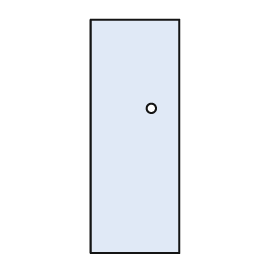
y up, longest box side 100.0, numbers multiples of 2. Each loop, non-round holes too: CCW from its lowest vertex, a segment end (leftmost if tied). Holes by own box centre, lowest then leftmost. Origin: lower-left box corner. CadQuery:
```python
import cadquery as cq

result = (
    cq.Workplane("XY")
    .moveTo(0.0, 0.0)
    .lineTo(38.0, 0.0)
    .lineTo(38.0, 100.0)
    .lineTo(0.0, 100.0)
    .close()
    .moveTo(26.0, 62.0)
    .circle(2.0)
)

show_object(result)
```